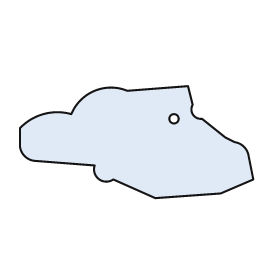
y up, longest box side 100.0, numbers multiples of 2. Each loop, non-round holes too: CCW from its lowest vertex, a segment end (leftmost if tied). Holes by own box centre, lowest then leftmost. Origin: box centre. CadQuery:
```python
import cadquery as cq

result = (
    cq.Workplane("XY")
    .moveTo(8.0, -24.0)
    .lineTo(36.0, -22.0)
    .lineTo(50.0, -16.0)
    .lineTo(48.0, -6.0)
    .threePointArc((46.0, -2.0), (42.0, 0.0))
    .lineTo(38.0, 2.0)
    .lineTo(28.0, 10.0)
    .threePointArc((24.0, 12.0), (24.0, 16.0))
    .lineTo(22.0, 24.0)
    .lineTo(-4.0, 22.0)
    .threePointArc((-18.0, 22.0), (-28.0, 12.0))
    .threePointArc((-40.0, 12.0), (-50.0, 6.0))
    .lineTo(-50.0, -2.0)
    .threePointArc((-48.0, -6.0), (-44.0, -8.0))
    .lineTo(-18.0, -10.0)
    .threePointArc((-16.0, -16.0), (-10.0, -16.0))
    .close()
    .moveTo(16.0, 10.0)
    .circle(2.0)
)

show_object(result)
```